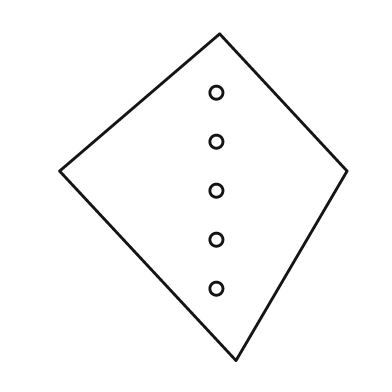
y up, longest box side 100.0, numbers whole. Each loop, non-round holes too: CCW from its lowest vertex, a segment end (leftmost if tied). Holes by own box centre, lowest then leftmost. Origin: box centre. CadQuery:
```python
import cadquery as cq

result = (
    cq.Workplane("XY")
    .moveTo(10.0, -50.0)
    .lineTo(44.0, 8.0)
    .lineTo(5.0, 50.0)
    .lineTo(-44.0, 8.0)
    .close()
    .moveTo(4.0, -28.0)
    .circle(2.0)
    .moveTo(4.0, -13.0)
    .circle(2.0)
    .moveTo(4.0, 2.0)
    .circle(2.0)
    .moveTo(4.0, 17.0)
    .circle(2.0)
    .moveTo(4.0, 32.0)
    .circle(2.0)
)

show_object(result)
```